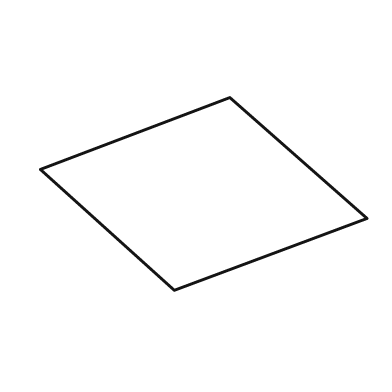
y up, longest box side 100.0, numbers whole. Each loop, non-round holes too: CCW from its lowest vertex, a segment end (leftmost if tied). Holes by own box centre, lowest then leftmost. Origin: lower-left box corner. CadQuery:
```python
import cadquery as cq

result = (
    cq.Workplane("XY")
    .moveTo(41.0, 0.0)
    .lineTo(100.0, 22.0)
    .lineTo(58.0, 59.0)
    .lineTo(0.0, 37.0)
    .close()
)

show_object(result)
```